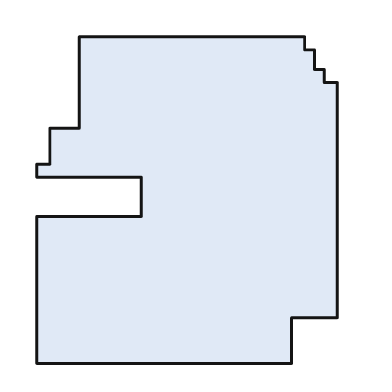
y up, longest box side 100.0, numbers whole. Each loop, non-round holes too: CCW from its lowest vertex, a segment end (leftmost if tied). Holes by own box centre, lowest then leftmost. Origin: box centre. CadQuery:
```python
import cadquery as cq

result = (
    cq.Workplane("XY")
    .moveTo(-46.0, -50.0)
    .lineTo(32.0, -50.0)
    .lineTo(32.0, -36.0)
    .lineTo(46.0, -36.0)
    .lineTo(46.0, 36.0)
    .lineTo(42.0, 36.0)
    .lineTo(42.0, 40.0)
    .lineTo(39.0, 40.0)
    .lineTo(39.0, 46.0)
    .lineTo(36.0, 46.0)
    .lineTo(36.0, 50.0)
    .lineTo(-33.0, 50.0)
    .lineTo(-33.0, 22.0)
    .lineTo(-42.0, 22.0)
    .lineTo(-42.0, 11.0)
    .lineTo(-46.0, 11.0)
    .lineTo(-46.0, 7.0)
    .lineTo(-14.0, 7.0)
    .lineTo(-14.0, -5.0)
    .lineTo(-46.0, -5.0)
    .close()
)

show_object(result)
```